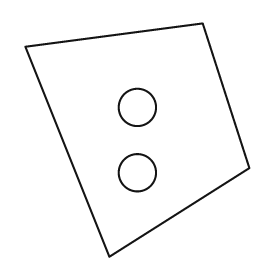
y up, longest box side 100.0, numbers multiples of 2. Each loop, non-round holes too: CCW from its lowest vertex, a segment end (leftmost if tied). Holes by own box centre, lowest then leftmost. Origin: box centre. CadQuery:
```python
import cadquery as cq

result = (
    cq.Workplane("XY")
    .moveTo(-12.0, -50.0)
    .lineTo(48.0, -12.0)
    .lineTo(28.0, 50.0)
    .lineTo(-48.0, 40.0)
    .close()
    .moveTo(0.0, -14.0)
    .circle(8.0)
    .moveTo(0.0, 14.0)
    .circle(8.0)
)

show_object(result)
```